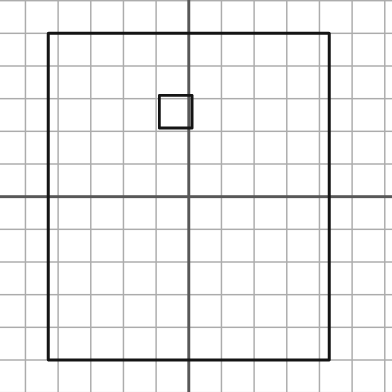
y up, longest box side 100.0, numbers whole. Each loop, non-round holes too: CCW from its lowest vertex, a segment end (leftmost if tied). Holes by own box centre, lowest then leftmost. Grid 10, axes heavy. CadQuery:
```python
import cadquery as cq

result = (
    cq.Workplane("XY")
    .moveTo(-43.0, -50.0)
    .lineTo(43.0, -50.0)
    .lineTo(43.0, 50.0)
    .lineTo(-43.0, 50.0)
    .close()
    .moveTo(-9.0, 21.0)
    .lineTo(1.0, 21.0)
    .lineTo(1.0, 31.0)
    .lineTo(-9.0, 31.0)
    .close()
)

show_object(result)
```